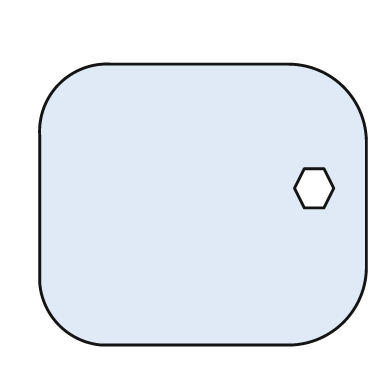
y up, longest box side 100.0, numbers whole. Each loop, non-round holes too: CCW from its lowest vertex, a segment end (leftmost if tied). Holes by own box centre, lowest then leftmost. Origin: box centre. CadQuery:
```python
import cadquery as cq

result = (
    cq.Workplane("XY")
    .moveTo(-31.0, -43.0)
    .lineTo(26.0, -43.0)
    .threePointArc((43.0, -36.0), (50.0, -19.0))
    .lineTo(50.0, 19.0)
    .threePointArc((43.0, 36.0), (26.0, 43.0))
    .lineTo(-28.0, 43.0)
    .threePointArc((-44.0, 37.0), (-50.0, 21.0))
    .lineTo(-50.0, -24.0)
    .threePointArc((-44.0, -37.0), (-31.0, -43.0))
    .close()
    .moveTo(31.0, -1.0)
    .lineTo(37.0, -1.0)
    .lineTo(40.0, 5.0)
    .lineTo(37.0, 11.0)
    .lineTo(31.0, 11.0)
    .lineTo(28.0, 5.0)
    .close()
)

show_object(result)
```